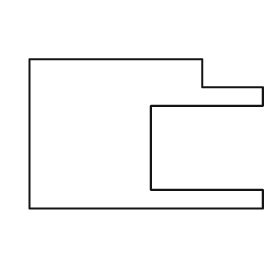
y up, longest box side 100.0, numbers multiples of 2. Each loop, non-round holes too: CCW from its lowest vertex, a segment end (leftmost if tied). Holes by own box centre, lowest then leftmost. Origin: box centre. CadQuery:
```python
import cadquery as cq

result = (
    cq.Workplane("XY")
    .moveTo(-50.0, -32.0)
    .lineTo(50.0, -32.0)
    .lineTo(50.0, -24.0)
    .lineTo(2.0, -24.0)
    .lineTo(2.0, 12.0)
    .lineTo(50.0, 12.0)
    .lineTo(50.0, 20.0)
    .lineTo(24.0, 20.0)
    .lineTo(24.0, 32.0)
    .lineTo(-50.0, 32.0)
    .close()
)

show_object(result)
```